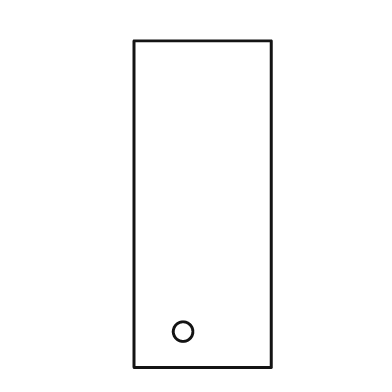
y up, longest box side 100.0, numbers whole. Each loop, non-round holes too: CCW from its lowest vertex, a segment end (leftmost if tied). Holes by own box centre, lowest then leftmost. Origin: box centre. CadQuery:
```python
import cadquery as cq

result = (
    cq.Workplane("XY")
    .moveTo(-21.0, -50.0)
    .lineTo(21.0, -50.0)
    .lineTo(21.0, 50.0)
    .lineTo(-21.0, 50.0)
    .close()
    .moveTo(-6.0, -39.0)
    .circle(3.0)
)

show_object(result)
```